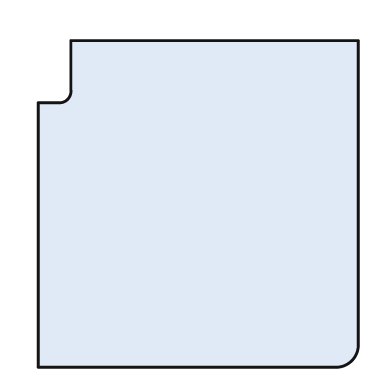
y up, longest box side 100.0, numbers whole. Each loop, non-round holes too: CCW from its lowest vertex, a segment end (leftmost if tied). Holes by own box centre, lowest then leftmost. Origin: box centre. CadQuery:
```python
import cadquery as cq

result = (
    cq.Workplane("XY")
    .moveTo(-49.0, -50.0)
    .lineTo(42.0, -50.0)
    .threePointArc((47.0, -48.0), (49.0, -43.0))
    .lineTo(49.0, 50.0)
    .lineTo(-39.0, 50.0)
    .lineTo(-39.0, 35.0)
    .threePointArc((-40.0, 32.0), (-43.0, 31.0))
    .lineTo(-49.0, 31.0)
    .close()
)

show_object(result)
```